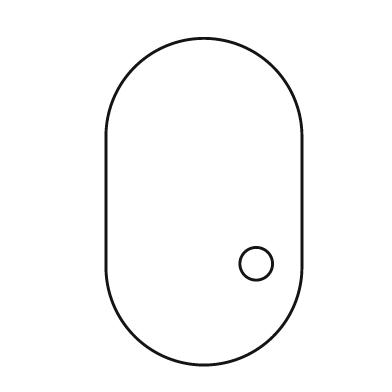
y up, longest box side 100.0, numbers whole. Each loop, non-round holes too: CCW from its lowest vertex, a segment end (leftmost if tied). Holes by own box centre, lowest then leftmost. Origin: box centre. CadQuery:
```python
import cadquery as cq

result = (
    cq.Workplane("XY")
    .moveTo(-30.0, -20.0)
    .threePointArc((0.0, -50.0), (30.0, -20.0))
    .lineTo(30.0, 20.0)
    .threePointArc((0.0, 50.0), (-30.0, 20.0))
    .close()
    .moveTo(16.0, -19.0)
    .circle(5.0)
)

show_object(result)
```